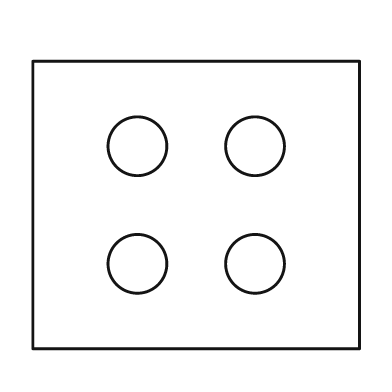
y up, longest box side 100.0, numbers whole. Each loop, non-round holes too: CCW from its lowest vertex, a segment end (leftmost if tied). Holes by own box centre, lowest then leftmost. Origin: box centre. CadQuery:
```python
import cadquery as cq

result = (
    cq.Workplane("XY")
    .moveTo(-50.0, -44.0)
    .lineTo(50.0, -44.0)
    .lineTo(50.0, 44.0)
    .lineTo(-50.0, 44.0)
    .close()
    .moveTo(-18.0, -18.0)
    .circle(9.0)
    .moveTo(18.0, -18.0)
    .circle(9.0)
    .moveTo(-18.0, 18.0)
    .circle(9.0)
    .moveTo(18.0, 18.0)
    .circle(9.0)
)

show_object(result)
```